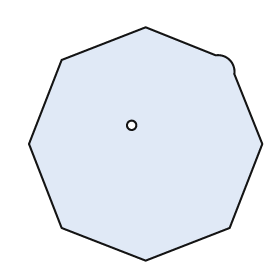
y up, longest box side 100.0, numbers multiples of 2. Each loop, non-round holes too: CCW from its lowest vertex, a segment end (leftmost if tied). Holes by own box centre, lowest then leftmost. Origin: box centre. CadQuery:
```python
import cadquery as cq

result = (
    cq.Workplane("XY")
    .moveTo(0.0, -50.0)
    .lineTo(36.0, -36.0)
    .lineTo(50.0, 0.0)
    .lineTo(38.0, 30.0)
    .threePointArc((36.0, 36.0), (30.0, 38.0))
    .lineTo(0.0, 50.0)
    .lineTo(-36.0, 36.0)
    .lineTo(-50.0, 0.0)
    .lineTo(-36.0, -36.0)
    .close()
    .moveTo(-6.0, 8.0)
    .circle(2.0)
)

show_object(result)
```